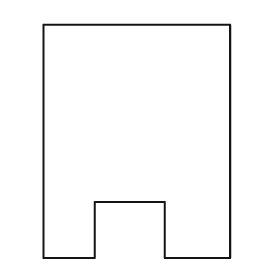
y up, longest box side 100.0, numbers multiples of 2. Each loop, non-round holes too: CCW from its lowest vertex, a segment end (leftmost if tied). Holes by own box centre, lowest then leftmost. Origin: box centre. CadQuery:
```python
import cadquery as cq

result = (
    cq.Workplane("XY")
    .moveTo(-40.0, -50.0)
    .lineTo(-18.0, -50.0)
    .lineTo(-18.0, -26.0)
    .lineTo(12.0, -26.0)
    .lineTo(12.0, -50.0)
    .lineTo(40.0, -50.0)
    .lineTo(40.0, 50.0)
    .lineTo(-40.0, 50.0)
    .close()
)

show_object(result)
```